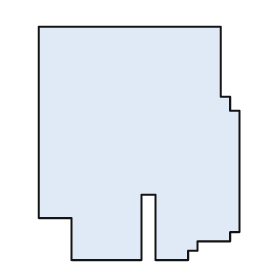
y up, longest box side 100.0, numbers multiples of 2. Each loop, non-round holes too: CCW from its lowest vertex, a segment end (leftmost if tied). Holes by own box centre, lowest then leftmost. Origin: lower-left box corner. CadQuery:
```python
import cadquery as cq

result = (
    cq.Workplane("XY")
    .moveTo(14.0, 0.0)
    .lineTo(44.0, 0.0)
    .lineTo(44.0, 28.0)
    .lineTo(50.0, 28.0)
    .lineTo(50.0, 0.0)
    .lineTo(64.0, 0.0)
    .lineTo(64.0, 4.0)
    .lineTo(68.0, 4.0)
    .lineTo(68.0, 8.0)
    .lineTo(82.0, 8.0)
    .lineTo(82.0, 12.0)
    .lineTo(86.0, 12.0)
    .lineTo(86.0, 64.0)
    .lineTo(82.0, 64.0)
    .lineTo(82.0, 70.0)
    .lineTo(78.0, 70.0)
    .lineTo(78.0, 100.0)
    .lineTo(0.0, 100.0)
    .lineTo(0.0, 18.0)
    .lineTo(14.0, 18.0)
    .close()
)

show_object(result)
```